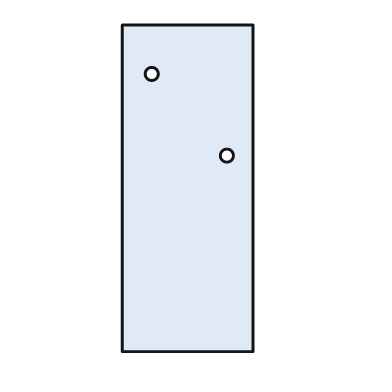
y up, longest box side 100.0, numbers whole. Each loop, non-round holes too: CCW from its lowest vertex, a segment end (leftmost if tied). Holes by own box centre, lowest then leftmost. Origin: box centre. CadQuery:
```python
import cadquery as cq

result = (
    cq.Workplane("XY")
    .moveTo(-20.0, -50.0)
    .lineTo(20.0, -50.0)
    .lineTo(20.0, 50.0)
    .lineTo(-20.0, 50.0)
    .close()
    .moveTo(12.0, 10.0)
    .circle(2.0)
    .moveTo(-11.0, 35.0)
    .circle(2.0)
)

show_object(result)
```